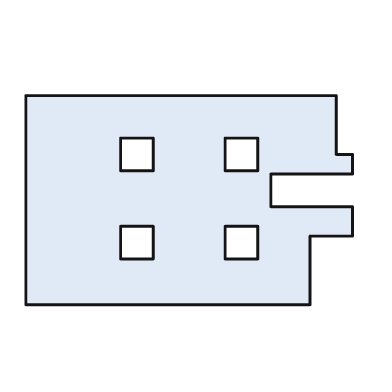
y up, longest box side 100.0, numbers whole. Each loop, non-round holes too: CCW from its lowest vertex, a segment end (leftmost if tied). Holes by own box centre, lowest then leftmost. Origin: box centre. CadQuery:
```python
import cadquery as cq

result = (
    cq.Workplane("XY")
    .moveTo(-50.0, -32.0)
    .lineTo(37.0, -32.0)
    .lineTo(37.0, -11.0)
    .lineTo(50.0, -11.0)
    .lineTo(50.0, -2.0)
    .lineTo(25.0, -2.0)
    .lineTo(25.0, 8.0)
    .lineTo(50.0, 8.0)
    .lineTo(50.0, 14.0)
    .lineTo(45.0, 14.0)
    .lineTo(45.0, 32.0)
    .lineTo(-50.0, 32.0)
    .close()
    .moveTo(-21.0, -18.0)
    .lineTo(-11.0, -18.0)
    .lineTo(-11.0, -8.0)
    .lineTo(-21.0, -8.0)
    .close()
    .moveTo(11.0, -18.0)
    .lineTo(21.0, -18.0)
    .lineTo(21.0, -8.0)
    .lineTo(11.0, -8.0)
    .close()
    .moveTo(-21.0, 9.0)
    .lineTo(-11.0, 9.0)
    .lineTo(-11.0, 19.0)
    .lineTo(-21.0, 19.0)
    .close()
    .moveTo(11.0, 9.0)
    .lineTo(21.0, 9.0)
    .lineTo(21.0, 19.0)
    .lineTo(11.0, 19.0)
    .close()
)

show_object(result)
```